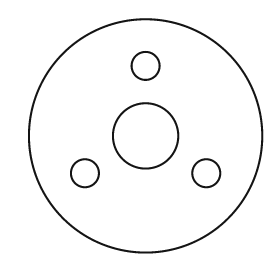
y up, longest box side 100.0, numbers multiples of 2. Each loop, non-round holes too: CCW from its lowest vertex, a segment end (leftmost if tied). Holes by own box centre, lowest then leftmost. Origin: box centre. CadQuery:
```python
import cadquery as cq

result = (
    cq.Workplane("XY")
    .moveTo(0.0, 0.0)
    .circle(50.0)
    .moveTo(-26.0, -16.0)
    .circle(6.0)
    .moveTo(26.0, -16.0)
    .circle(6.0)
    .moveTo(0.0, 0.0)
    .circle(14.0)
    .moveTo(0.0, 30.0)
    .circle(6.0)
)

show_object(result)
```